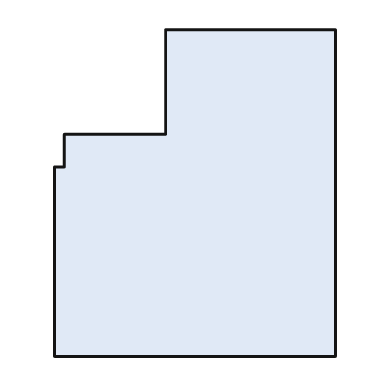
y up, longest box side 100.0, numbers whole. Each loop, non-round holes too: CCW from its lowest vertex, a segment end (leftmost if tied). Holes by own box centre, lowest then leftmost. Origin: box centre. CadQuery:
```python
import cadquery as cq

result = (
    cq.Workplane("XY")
    .moveTo(-43.0, -50.0)
    .lineTo(43.0, -50.0)
    .lineTo(43.0, 50.0)
    .lineTo(-9.0, 50.0)
    .lineTo(-9.0, 18.0)
    .lineTo(-40.0, 18.0)
    .lineTo(-40.0, 8.0)
    .lineTo(-43.0, 8.0)
    .close()
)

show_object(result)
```